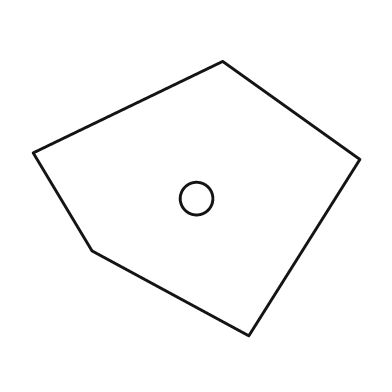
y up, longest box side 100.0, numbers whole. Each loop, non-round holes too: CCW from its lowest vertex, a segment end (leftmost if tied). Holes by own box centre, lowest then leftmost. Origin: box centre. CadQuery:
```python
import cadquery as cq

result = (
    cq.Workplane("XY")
    .moveTo(16.0, -42.0)
    .lineTo(50.0, 12.0)
    .lineTo(8.0, 42.0)
    .lineTo(-50.0, 14.0)
    .lineTo(-32.0, -16.0)
    .close()
    .moveTo(0.0, 0.0)
    .circle(5.0)
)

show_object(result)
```